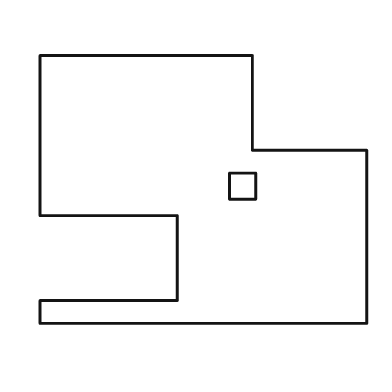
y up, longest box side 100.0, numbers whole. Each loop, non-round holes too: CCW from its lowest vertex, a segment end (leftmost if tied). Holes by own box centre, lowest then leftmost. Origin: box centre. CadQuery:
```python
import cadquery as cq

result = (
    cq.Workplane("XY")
    .moveTo(-50.0, -41.0)
    .lineTo(50.0, -41.0)
    .lineTo(50.0, 12.0)
    .lineTo(15.0, 12.0)
    .lineTo(15.0, 41.0)
    .lineTo(-50.0, 41.0)
    .lineTo(-50.0, -8.0)
    .lineTo(-8.0, -8.0)
    .lineTo(-8.0, -34.0)
    .lineTo(-50.0, -34.0)
    .close()
    .moveTo(8.0, -3.0)
    .lineTo(16.0, -3.0)
    .lineTo(16.0, 5.0)
    .lineTo(8.0, 5.0)
    .close()
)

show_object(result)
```